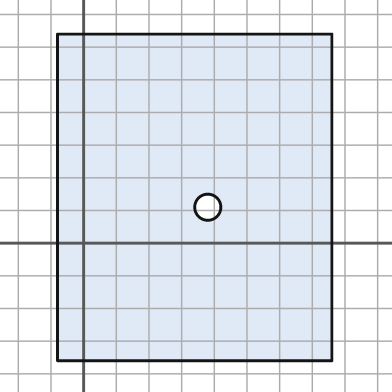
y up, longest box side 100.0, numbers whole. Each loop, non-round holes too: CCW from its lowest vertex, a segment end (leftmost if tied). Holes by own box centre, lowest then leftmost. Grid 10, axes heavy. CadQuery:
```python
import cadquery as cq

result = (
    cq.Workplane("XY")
    .moveTo(-8.0, -36.0)
    .lineTo(76.0, -36.0)
    .lineTo(76.0, 64.0)
    .lineTo(-8.0, 64.0)
    .close()
    .moveTo(38.0, 11.0)
    .circle(4.0)
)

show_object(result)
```